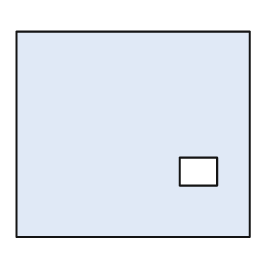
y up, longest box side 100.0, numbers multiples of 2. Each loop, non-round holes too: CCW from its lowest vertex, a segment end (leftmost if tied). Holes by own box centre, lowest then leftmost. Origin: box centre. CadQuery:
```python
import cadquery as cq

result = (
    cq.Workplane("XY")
    .moveTo(-50.0, -44.0)
    .lineTo(50.0, -44.0)
    .lineTo(50.0, 44.0)
    .lineTo(-50.0, 44.0)
    .close()
    .moveTo(20.0, -22.0)
    .lineTo(36.0, -22.0)
    .lineTo(36.0, -10.0)
    .lineTo(20.0, -10.0)
    .close()
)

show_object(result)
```